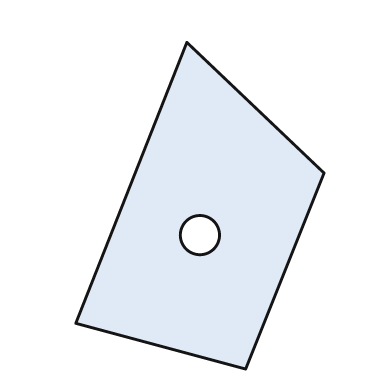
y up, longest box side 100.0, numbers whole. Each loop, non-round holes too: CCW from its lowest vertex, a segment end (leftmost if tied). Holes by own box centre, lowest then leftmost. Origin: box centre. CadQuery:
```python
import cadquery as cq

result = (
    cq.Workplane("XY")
    .moveTo(14.0, -50.0)
    .lineTo(38.0, 10.0)
    .lineTo(-4.0, 50.0)
    .lineTo(-38.0, -36.0)
    .close()
    .moveTo(0.0, -9.0)
    .circle(6.0)
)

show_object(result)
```